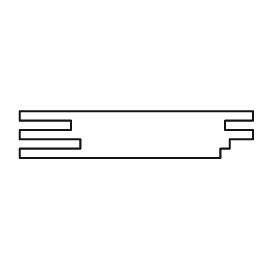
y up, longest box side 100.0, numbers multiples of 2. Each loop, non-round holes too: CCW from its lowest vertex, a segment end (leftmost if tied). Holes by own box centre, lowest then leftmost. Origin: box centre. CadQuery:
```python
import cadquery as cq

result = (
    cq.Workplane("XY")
    .moveTo(-50.0, -10.0)
    .lineTo(36.0, -10.0)
    .lineTo(36.0, -6.0)
    .lineTo(40.0, -6.0)
    .lineTo(40.0, -2.0)
    .lineTo(50.0, -2.0)
    .lineTo(50.0, 2.0)
    .lineTo(38.0, 2.0)
    .lineTo(38.0, 6.0)
    .lineTo(50.0, 6.0)
    .lineTo(50.0, 10.0)
    .lineTo(-50.0, 10.0)
    .lineTo(-50.0, 6.0)
    .lineTo(-28.0, 6.0)
    .lineTo(-28.0, 2.0)
    .lineTo(-50.0, 2.0)
    .lineTo(-50.0, -2.0)
    .lineTo(-24.0, -2.0)
    .lineTo(-24.0, -6.0)
    .lineTo(-50.0, -6.0)
    .close()
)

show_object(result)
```